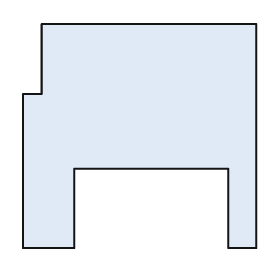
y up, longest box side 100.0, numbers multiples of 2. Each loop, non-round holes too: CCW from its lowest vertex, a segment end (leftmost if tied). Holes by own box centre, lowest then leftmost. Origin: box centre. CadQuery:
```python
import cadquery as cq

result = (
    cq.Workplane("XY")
    .moveTo(-50.0, -48.0)
    .lineTo(-28.0, -48.0)
    .lineTo(-28.0, -14.0)
    .lineTo(38.0, -14.0)
    .lineTo(38.0, -48.0)
    .lineTo(50.0, -48.0)
    .lineTo(50.0, 48.0)
    .lineTo(-42.0, 48.0)
    .lineTo(-42.0, 18.0)
    .lineTo(-50.0, 18.0)
    .close()
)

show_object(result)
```